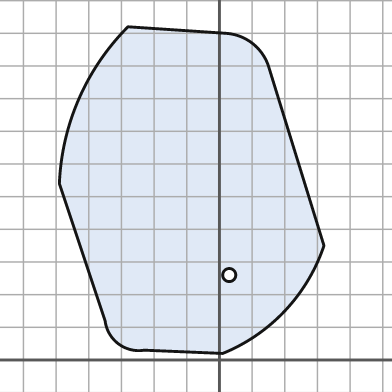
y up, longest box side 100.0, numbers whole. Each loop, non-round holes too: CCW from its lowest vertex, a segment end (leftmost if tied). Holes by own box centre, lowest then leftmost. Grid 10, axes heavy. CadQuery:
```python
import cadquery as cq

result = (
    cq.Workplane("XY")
    .moveTo(1.0, 2.0)
    .threePointArc((20.0, 15.0), (32.0, 35.0))
    .lineTo(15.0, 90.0)
    .threePointArc((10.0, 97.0), (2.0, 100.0))
    .lineTo(-28.0, 102.0)
    .threePointArc((-43.0, 80.0), (-49.0, 54.0))
    .lineTo(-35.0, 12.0)
    .threePointArc((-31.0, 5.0), (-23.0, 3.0))
    .close()
    .moveTo(3.0, 26.0)
    .circle(2.0)
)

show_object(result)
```